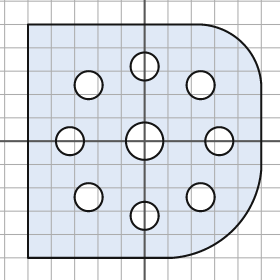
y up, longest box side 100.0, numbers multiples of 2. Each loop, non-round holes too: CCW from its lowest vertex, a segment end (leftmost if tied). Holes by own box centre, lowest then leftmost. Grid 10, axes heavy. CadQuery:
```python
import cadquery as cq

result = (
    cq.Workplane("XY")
    .moveTo(-50.0, -50.0)
    .lineTo(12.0, -50.0)
    .threePointArc((38.0, -38.0), (50.0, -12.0))
    .lineTo(50.0, 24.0)
    .threePointArc((42.0, 42.0), (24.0, 50.0))
    .lineTo(-50.0, 50.0)
    .close()
    .moveTo(0.0, -32.0)
    .circle(6.0)
    .moveTo(-24.0, -24.0)
    .circle(6.0)
    .moveTo(24.0, -24.0)
    .circle(6.0)
    .moveTo(-32.0, 0.0)
    .circle(6.0)
    .moveTo(0.0, 0.0)
    .circle(8.0)
    .moveTo(32.0, 0.0)
    .circle(6.0)
    .moveTo(-24.0, 24.0)
    .circle(6.0)
    .moveTo(24.0, 24.0)
    .circle(6.0)
    .moveTo(0.0, 32.0)
    .circle(6.0)
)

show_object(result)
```